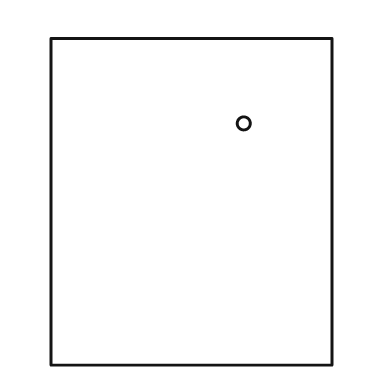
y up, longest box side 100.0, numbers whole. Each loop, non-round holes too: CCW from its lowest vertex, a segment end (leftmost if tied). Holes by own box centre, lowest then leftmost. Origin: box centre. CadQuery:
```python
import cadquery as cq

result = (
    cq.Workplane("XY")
    .moveTo(-43.0, -50.0)
    .lineTo(43.0, -50.0)
    .lineTo(43.0, 50.0)
    .lineTo(-43.0, 50.0)
    .close()
    .moveTo(16.0, 24.0)
    .circle(2.0)
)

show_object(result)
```